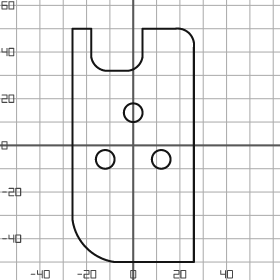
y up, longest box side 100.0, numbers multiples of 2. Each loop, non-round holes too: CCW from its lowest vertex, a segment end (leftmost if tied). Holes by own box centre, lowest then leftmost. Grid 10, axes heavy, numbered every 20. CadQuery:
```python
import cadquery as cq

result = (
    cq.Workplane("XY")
    .moveTo(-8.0, -50.0)
    .lineTo(26.0, -50.0)
    .lineTo(26.0, 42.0)
    .threePointArc((24.0, 48.0), (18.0, 50.0))
    .lineTo(4.0, 50.0)
    .lineTo(4.0, 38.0)
    .threePointArc((2.0, 34.0), (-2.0, 32.0))
    .lineTo(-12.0, 32.0)
    .threePointArc((-16.0, 34.0), (-18.0, 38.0))
    .lineTo(-18.0, 50.0)
    .lineTo(-26.0, 50.0)
    .lineTo(-26.0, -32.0)
    .threePointArc((-20.0, -44.0), (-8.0, -50.0))
    .close()
    .moveTo(-12.0, -6.0)
    .circle(4.0)
    .moveTo(12.0, -6.0)
    .circle(4.0)
    .moveTo(0.0, 14.0)
    .circle(4.0)
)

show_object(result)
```